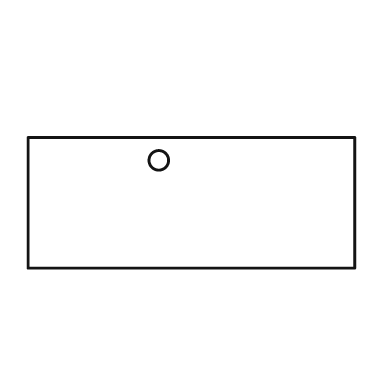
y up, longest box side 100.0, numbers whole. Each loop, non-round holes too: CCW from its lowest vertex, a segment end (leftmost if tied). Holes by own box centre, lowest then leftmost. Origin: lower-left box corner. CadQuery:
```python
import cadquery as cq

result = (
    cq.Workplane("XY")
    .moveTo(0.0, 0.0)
    .lineTo(100.0, 0.0)
    .lineTo(100.0, 40.0)
    .lineTo(0.0, 40.0)
    .close()
    .moveTo(40.0, 33.0)
    .circle(3.0)
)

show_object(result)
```